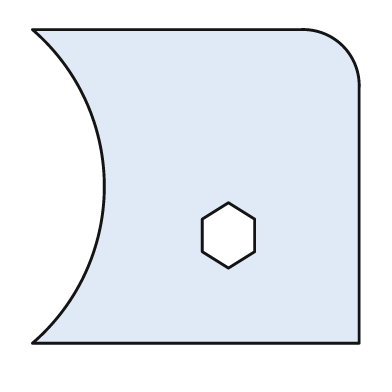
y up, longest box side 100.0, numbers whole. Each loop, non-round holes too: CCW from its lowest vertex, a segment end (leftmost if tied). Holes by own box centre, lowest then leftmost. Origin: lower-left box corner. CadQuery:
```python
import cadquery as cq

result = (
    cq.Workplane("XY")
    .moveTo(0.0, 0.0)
    .lineTo(100.0, 0.0)
    .lineTo(100.0, 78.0)
    .threePointArc((95.0, 91.0), (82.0, 96.0))
    .lineTo(0.0, 96.0)
    .threePointArc((22.0, 48.0), (0.0, 0.0))
    .close()
    .moveTo(60.0, 23.0)
    .lineTo(68.0, 28.0)
    .lineTo(68.0, 38.0)
    .lineTo(60.0, 43.0)
    .lineTo(52.0, 38.0)
    .lineTo(52.0, 28.0)
    .close()
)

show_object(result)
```